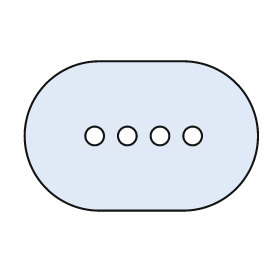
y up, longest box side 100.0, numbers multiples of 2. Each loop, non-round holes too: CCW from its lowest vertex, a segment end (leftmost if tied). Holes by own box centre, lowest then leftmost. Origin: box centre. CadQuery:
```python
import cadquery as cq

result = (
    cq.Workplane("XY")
    .moveTo(-18.0, -32.0)
    .lineTo(18.0, -32.0)
    .threePointArc((50.0, 0.0), (18.0, 32.0))
    .lineTo(-18.0, 32.0)
    .threePointArc((-50.0, 0.0), (-18.0, -32.0))
    .close()
    .moveTo(-20.0, 0.0)
    .circle(4.0)
    .moveTo(-6.0, 0.0)
    .circle(4.0)
    .moveTo(8.0, 0.0)
    .circle(4.0)
    .moveTo(22.0, 0.0)
    .circle(4.0)
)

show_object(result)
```